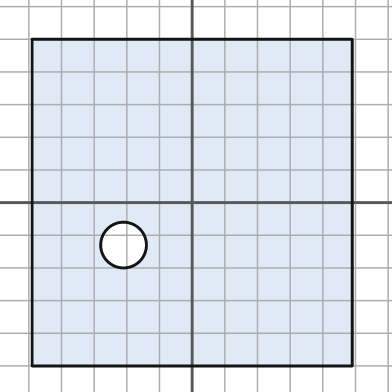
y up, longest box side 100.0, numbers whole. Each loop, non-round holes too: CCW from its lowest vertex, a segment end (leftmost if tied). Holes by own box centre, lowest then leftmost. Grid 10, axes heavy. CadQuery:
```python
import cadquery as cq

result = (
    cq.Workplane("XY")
    .moveTo(-49.0, -50.0)
    .lineTo(49.0, -50.0)
    .lineTo(49.0, 50.0)
    .lineTo(-49.0, 50.0)
    .close()
    .moveTo(-21.0, -13.0)
    .circle(7.0)
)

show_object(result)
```